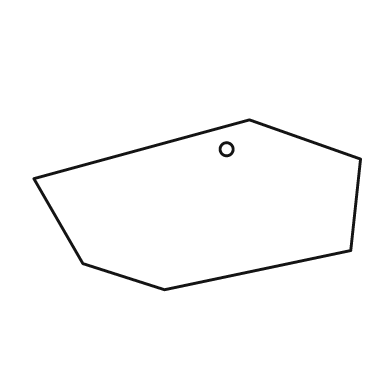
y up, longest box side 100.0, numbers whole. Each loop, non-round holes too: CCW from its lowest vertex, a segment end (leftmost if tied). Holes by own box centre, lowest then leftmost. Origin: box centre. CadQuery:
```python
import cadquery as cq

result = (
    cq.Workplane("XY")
    .moveTo(-10.0, -26.0)
    .lineTo(47.0, -14.0)
    .lineTo(50.0, 14.0)
    .lineTo(16.0, 26.0)
    .lineTo(-50.0, 8.0)
    .lineTo(-35.0, -18.0)
    .close()
    .moveTo(9.0, 17.0)
    .circle(2.0)
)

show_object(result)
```